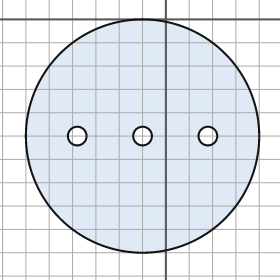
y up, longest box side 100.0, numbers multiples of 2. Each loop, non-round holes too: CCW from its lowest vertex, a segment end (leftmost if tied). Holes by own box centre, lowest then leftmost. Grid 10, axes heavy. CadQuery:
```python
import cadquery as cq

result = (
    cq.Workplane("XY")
    .moveTo(-10.0, -50.0)
    .circle(50.0)
    .moveTo(-38.0, -50.0)
    .circle(4.0)
    .moveTo(-10.0, -50.0)
    .circle(4.0)
    .moveTo(18.0, -50.0)
    .circle(4.0)
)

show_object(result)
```